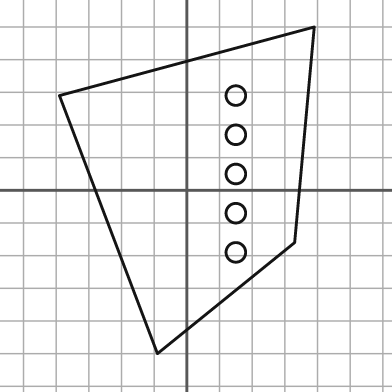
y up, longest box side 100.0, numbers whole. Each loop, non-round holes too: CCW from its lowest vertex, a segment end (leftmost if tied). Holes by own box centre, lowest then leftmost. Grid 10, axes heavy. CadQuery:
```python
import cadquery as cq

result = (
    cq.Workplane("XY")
    .moveTo(-9.0, -50.0)
    .lineTo(33.0, -16.0)
    .lineTo(39.0, 50.0)
    .lineTo(-39.0, 29.0)
    .close()
    .moveTo(15.0, -19.0)
    .circle(3.0)
    .moveTo(15.0, -7.0)
    .circle(3.0)
    .moveTo(15.0, 5.0)
    .circle(3.0)
    .moveTo(15.0, 17.0)
    .circle(3.0)
    .moveTo(15.0, 29.0)
    .circle(3.0)
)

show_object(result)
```